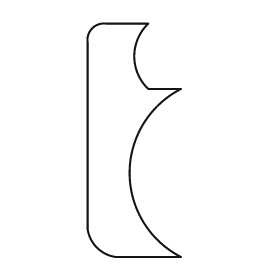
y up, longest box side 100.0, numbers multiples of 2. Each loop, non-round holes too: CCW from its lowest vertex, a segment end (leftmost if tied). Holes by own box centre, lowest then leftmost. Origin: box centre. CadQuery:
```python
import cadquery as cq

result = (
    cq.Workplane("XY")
    .moveTo(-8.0, -50.0)
    .lineTo(20.0, -50.0)
    .threePointArc((-2.0, -14.0), (20.0, 22.0))
    .lineTo(6.0, 22.0)
    .threePointArc((0.0, 36.0), (6.0, 50.0))
    .lineTo(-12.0, 50.0)
    .threePointArc((-18.0, 48.0), (-20.0, 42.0))
    .lineTo(-20.0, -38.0)
    .threePointArc((-16.0, -46.0), (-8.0, -50.0))
    .close()
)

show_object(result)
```